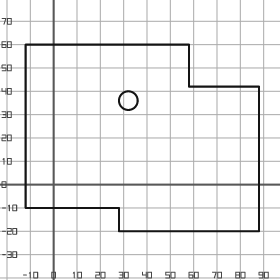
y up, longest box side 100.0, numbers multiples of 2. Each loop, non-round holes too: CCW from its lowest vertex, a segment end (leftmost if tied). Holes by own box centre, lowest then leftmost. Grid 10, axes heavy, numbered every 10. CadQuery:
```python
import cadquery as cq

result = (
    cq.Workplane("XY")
    .moveTo(28.0, -20.0)
    .lineTo(88.0, -20.0)
    .lineTo(88.0, 42.0)
    .lineTo(58.0, 42.0)
    .lineTo(58.0, 60.0)
    .lineTo(-12.0, 60.0)
    .lineTo(-12.0, -10.0)
    .lineTo(28.0, -10.0)
    .close()
    .moveTo(32.0, 36.0)
    .circle(4.0)
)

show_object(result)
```